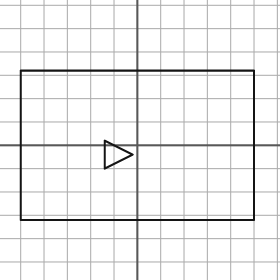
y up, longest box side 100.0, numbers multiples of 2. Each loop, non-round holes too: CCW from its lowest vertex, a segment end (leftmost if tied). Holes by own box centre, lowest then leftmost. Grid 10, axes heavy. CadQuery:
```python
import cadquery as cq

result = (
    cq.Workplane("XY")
    .moveTo(-50.0, -32.0)
    .lineTo(50.0, -32.0)
    .lineTo(50.0, 32.0)
    .lineTo(-50.0, 32.0)
    .close()
    .moveTo(-14.0, -10.0)
    .lineTo(-2.0, -4.0)
    .lineTo(-14.0, 2.0)
    .close()
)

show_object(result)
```